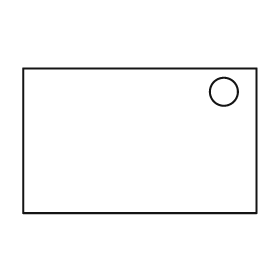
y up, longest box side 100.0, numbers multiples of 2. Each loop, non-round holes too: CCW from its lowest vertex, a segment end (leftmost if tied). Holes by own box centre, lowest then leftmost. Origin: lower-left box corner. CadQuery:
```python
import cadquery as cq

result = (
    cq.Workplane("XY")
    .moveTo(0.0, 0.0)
    .lineTo(100.0, 0.0)
    .lineTo(100.0, 62.0)
    .lineTo(0.0, 62.0)
    .close()
    .moveTo(86.0, 52.0)
    .circle(6.0)
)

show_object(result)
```